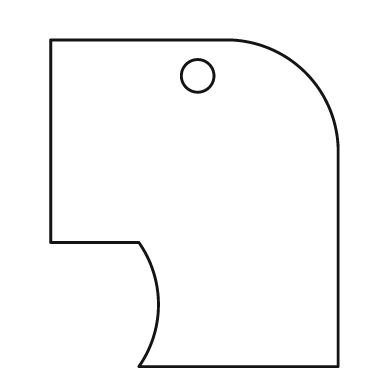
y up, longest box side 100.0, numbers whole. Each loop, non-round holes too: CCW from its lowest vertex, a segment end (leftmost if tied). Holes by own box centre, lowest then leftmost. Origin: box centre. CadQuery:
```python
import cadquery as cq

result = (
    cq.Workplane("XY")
    .moveTo(-17.0, -50.0)
    .lineTo(44.0, -50.0)
    .lineTo(44.0, 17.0)
    .threePointArc((34.0, 40.0), (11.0, 50.0))
    .lineTo(-44.0, 50.0)
    .lineTo(-44.0, -12.0)
    .lineTo(-17.0, -12.0)
    .threePointArc((-11.0, -31.0), (-17.0, -50.0))
    .close()
    .moveTo(1.0, 39.0)
    .circle(5.0)
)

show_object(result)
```